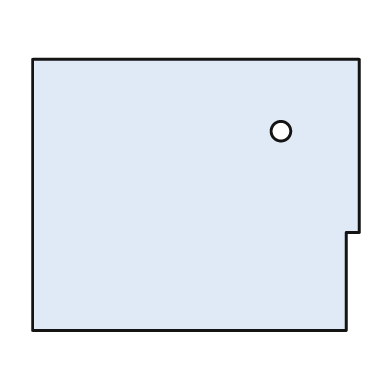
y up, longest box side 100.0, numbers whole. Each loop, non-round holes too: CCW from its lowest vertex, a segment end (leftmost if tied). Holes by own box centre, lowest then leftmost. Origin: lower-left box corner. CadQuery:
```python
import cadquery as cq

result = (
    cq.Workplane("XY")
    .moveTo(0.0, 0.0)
    .lineTo(96.0, 0.0)
    .lineTo(96.0, 30.0)
    .lineTo(100.0, 30.0)
    .lineTo(100.0, 83.0)
    .lineTo(0.0, 83.0)
    .close()
    .moveTo(76.0, 61.0)
    .circle(3.0)
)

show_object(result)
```